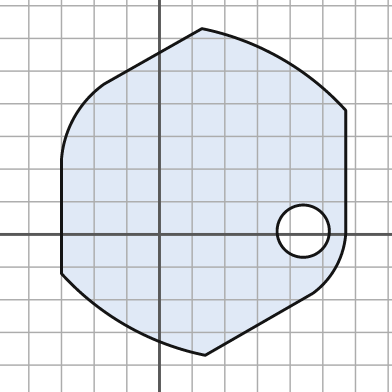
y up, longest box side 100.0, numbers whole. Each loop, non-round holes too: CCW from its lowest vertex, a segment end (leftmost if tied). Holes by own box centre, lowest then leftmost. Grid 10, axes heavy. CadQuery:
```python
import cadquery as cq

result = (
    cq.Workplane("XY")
    .moveTo(14.0, -37.0)
    .lineTo(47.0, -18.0)
    .threePointArc((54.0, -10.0), (57.0, 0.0))
    .lineTo(57.0, 38.0)
    .threePointArc((37.0, 54.0), (13.0, 63.0))
    .lineTo(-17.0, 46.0)
    .threePointArc((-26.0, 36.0), (-30.0, 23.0))
    .lineTo(-30.0, -12.0)
    .threePointArc((-10.0, -28.0), (14.0, -37.0))
    .close()
    .moveTo(44.0, 1.0)
    .circle(8.0)
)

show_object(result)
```